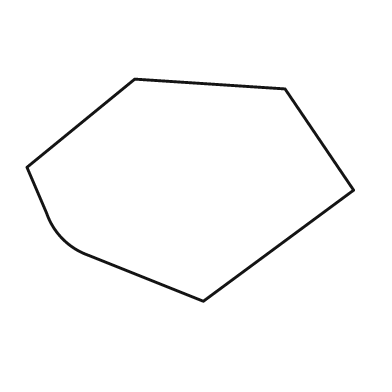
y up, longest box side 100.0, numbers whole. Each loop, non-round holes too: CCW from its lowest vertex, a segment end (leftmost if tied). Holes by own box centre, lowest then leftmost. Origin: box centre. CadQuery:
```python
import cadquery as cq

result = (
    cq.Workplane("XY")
    .moveTo(4.0, -34.0)
    .lineTo(50.0, 0.0)
    .lineTo(29.0, 31.0)
    .lineTo(-17.0, 34.0)
    .lineTo(-50.0, 7.0)
    .lineTo(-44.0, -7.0)
    .threePointArc((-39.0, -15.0), (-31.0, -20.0))
    .close()
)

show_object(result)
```